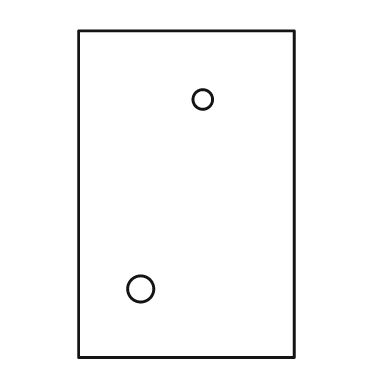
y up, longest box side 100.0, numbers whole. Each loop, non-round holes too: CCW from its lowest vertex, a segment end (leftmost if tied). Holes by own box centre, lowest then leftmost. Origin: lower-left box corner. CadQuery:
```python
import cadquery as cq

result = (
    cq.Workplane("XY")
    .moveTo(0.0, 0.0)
    .lineTo(66.0, 0.0)
    .lineTo(66.0, 100.0)
    .lineTo(0.0, 100.0)
    .close()
    .moveTo(19.0, 21.0)
    .circle(4.0)
    .moveTo(38.0, 79.0)
    .circle(3.0)
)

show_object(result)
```